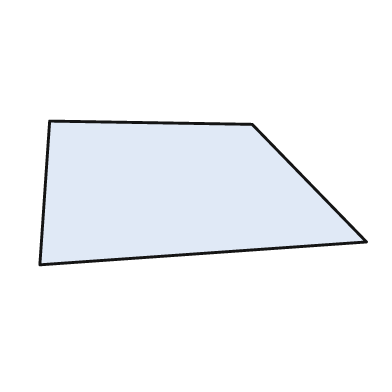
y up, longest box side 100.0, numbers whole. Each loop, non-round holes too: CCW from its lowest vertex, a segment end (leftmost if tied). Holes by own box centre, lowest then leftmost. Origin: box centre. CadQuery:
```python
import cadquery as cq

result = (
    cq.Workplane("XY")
    .moveTo(-50.0, -22.0)
    .lineTo(50.0, -15.0)
    .lineTo(15.0, 21.0)
    .lineTo(-47.0, 22.0)
    .close()
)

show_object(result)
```